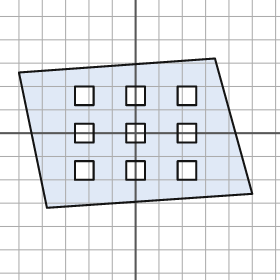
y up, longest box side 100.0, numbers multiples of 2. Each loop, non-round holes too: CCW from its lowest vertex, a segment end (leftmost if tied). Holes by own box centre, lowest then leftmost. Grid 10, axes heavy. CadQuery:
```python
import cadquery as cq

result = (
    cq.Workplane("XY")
    .moveTo(-38.0, -32.0)
    .lineTo(50.0, -26.0)
    .lineTo(34.0, 32.0)
    .lineTo(-50.0, 26.0)
    .close()
    .moveTo(-26.0, -20.0)
    .lineTo(-18.0, -20.0)
    .lineTo(-18.0, -12.0)
    .lineTo(-26.0, -12.0)
    .close()
    .moveTo(-4.0, -20.0)
    .lineTo(4.0, -20.0)
    .lineTo(4.0, -12.0)
    .lineTo(-4.0, -12.0)
    .close()
    .moveTo(18.0, -20.0)
    .lineTo(26.0, -20.0)
    .lineTo(26.0, -12.0)
    .lineTo(18.0, -12.0)
    .close()
    .moveTo(-26.0, -4.0)
    .lineTo(-18.0, -4.0)
    .lineTo(-18.0, 4.0)
    .lineTo(-26.0, 4.0)
    .close()
    .moveTo(-4.0, -4.0)
    .lineTo(4.0, -4.0)
    .lineTo(4.0, 4.0)
    .lineTo(-4.0, 4.0)
    .close()
    .moveTo(18.0, -4.0)
    .lineTo(26.0, -4.0)
    .lineTo(26.0, 4.0)
    .lineTo(18.0, 4.0)
    .close()
    .moveTo(-26.0, 12.0)
    .lineTo(-18.0, 12.0)
    .lineTo(-18.0, 20.0)
    .lineTo(-26.0, 20.0)
    .close()
    .moveTo(-4.0, 12.0)
    .lineTo(4.0, 12.0)
    .lineTo(4.0, 20.0)
    .lineTo(-4.0, 20.0)
    .close()
    .moveTo(18.0, 12.0)
    .lineTo(26.0, 12.0)
    .lineTo(26.0, 20.0)
    .lineTo(18.0, 20.0)
    .close()
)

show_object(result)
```